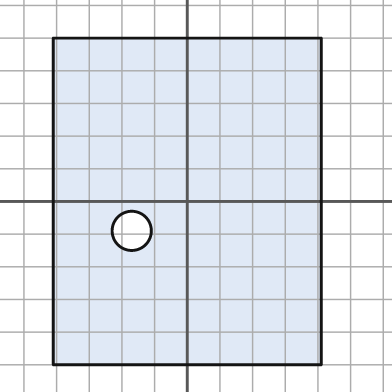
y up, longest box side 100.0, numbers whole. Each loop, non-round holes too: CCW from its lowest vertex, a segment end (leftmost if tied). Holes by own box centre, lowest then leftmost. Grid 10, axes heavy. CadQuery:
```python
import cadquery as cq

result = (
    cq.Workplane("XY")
    .moveTo(-41.0, -50.0)
    .lineTo(41.0, -50.0)
    .lineTo(41.0, 50.0)
    .lineTo(-41.0, 50.0)
    .close()
    .moveTo(-17.0, -9.0)
    .circle(6.0)
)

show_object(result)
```